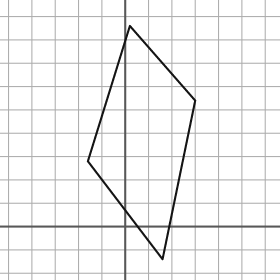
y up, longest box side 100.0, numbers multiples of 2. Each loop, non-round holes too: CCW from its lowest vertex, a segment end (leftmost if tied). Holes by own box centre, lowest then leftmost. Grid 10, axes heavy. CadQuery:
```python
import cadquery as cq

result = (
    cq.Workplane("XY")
    .moveTo(16.0, -14.0)
    .lineTo(30.0, 54.0)
    .lineTo(2.0, 86.0)
    .lineTo(-16.0, 28.0)
    .close()
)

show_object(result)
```